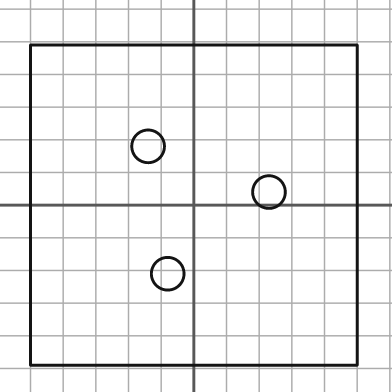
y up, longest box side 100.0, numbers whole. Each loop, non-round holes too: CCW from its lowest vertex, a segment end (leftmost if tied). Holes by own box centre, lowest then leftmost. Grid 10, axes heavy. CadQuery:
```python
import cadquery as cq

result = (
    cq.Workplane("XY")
    .moveTo(-50.0, -49.0)
    .lineTo(50.0, -49.0)
    .lineTo(50.0, 49.0)
    .lineTo(-50.0, 49.0)
    .close()
    .moveTo(-8.0, -21.0)
    .circle(5.0)
    .moveTo(23.0, 4.0)
    .circle(5.0)
    .moveTo(-14.0, 18.0)
    .circle(5.0)
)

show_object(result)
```